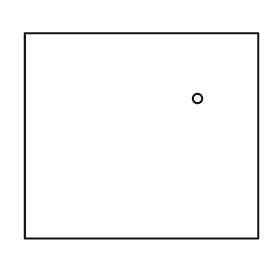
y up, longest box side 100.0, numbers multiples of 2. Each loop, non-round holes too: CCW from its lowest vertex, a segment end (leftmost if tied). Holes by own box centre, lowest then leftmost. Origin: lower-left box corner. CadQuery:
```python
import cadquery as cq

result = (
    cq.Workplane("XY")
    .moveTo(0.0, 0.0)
    .lineTo(100.0, 0.0)
    .lineTo(100.0, 88.0)
    .lineTo(0.0, 88.0)
    .close()
    .moveTo(74.0, 60.0)
    .circle(2.0)
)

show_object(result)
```